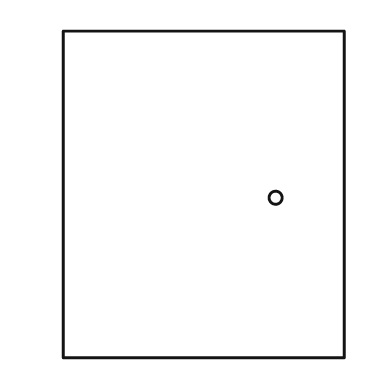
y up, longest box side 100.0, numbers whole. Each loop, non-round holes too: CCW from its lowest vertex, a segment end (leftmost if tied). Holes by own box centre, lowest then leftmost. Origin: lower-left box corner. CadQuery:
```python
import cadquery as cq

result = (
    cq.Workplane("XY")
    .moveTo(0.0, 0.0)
    .lineTo(86.0, 0.0)
    .lineTo(86.0, 100.0)
    .lineTo(0.0, 100.0)
    .close()
    .moveTo(65.0, 49.0)
    .circle(2.0)
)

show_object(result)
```